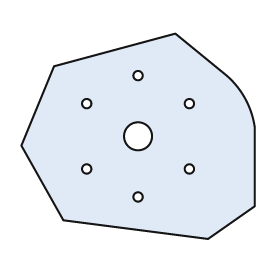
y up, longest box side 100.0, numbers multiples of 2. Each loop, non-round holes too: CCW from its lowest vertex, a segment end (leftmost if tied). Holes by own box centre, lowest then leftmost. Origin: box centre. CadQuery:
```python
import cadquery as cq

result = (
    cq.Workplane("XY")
    .moveTo(30.0, -44.0)
    .lineTo(50.0, -30.0)
    .lineTo(50.0, 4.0)
    .threePointArc((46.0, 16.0), (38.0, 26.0))
    .lineTo(16.0, 44.0)
    .lineTo(-36.0, 30.0)
    .lineTo(-50.0, -4.0)
    .lineTo(-32.0, -36.0)
    .close()
    .moveTo(0.0, -26.0)
    .circle(2.0)
    .moveTo(-22.0, -14.0)
    .circle(2.0)
    .moveTo(22.0, -14.0)
    .circle(2.0)
    .moveTo(0.0, 0.0)
    .circle(6.0)
    .moveTo(-22.0, 14.0)
    .circle(2.0)
    .moveTo(22.0, 14.0)
    .circle(2.0)
    .moveTo(0.0, 26.0)
    .circle(2.0)
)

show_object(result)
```